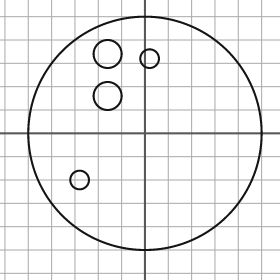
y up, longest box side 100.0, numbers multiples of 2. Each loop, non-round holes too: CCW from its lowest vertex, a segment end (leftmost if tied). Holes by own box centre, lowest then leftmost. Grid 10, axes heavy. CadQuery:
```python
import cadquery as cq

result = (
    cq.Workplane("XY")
    .moveTo(0.0, 0.0)
    .circle(50.0)
    .moveTo(-28.0, -20.0)
    .circle(4.0)
    .moveTo(-16.0, 16.0)
    .circle(6.0)
    .moveTo(2.0, 32.0)
    .circle(4.0)
    .moveTo(-16.0, 34.0)
    .circle(6.0)
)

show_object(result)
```